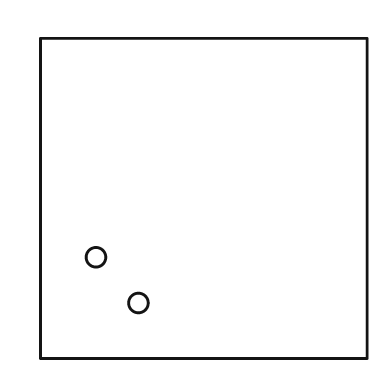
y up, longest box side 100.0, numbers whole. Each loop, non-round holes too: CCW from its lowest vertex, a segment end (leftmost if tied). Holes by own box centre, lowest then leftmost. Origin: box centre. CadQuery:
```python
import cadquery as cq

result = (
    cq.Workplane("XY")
    .moveTo(-50.0, -49.0)
    .lineTo(50.0, -49.0)
    .lineTo(50.0, 49.0)
    .lineTo(-50.0, 49.0)
    .close()
    .moveTo(-20.0, -32.0)
    .circle(3.0)
    .moveTo(-33.0, -18.0)
    .circle(3.0)
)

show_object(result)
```